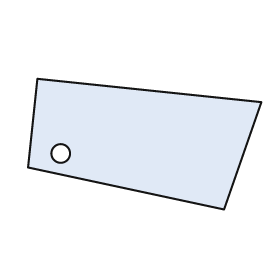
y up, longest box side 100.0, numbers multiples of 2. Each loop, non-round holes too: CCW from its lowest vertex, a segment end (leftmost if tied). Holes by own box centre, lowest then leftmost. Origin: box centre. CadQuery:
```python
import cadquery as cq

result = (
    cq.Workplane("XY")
    .moveTo(34.0, -28.0)
    .lineTo(50.0, 18.0)
    .lineTo(-46.0, 28.0)
    .lineTo(-50.0, -10.0)
    .close()
    .moveTo(-36.0, -4.0)
    .circle(4.0)
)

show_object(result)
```